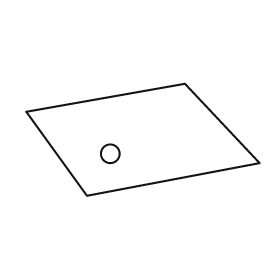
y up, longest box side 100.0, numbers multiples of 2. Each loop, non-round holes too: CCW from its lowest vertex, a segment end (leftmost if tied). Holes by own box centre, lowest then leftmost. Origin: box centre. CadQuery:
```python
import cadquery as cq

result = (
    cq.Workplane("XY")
    .moveTo(-24.0, -24.0)
    .lineTo(50.0, -10.0)
    .lineTo(18.0, 24.0)
    .lineTo(-50.0, 12.0)
    .close()
    .moveTo(-14.0, -6.0)
    .circle(4.0)
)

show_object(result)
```